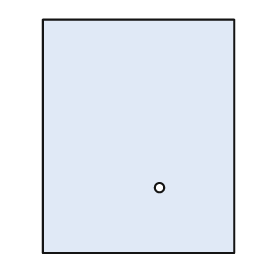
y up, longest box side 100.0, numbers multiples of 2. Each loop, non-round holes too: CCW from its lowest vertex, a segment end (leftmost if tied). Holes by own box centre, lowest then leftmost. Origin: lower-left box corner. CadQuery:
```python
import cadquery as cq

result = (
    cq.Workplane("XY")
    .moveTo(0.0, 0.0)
    .lineTo(82.0, 0.0)
    .lineTo(82.0, 100.0)
    .lineTo(0.0, 100.0)
    .close()
    .moveTo(50.0, 28.0)
    .circle(2.0)
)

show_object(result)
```